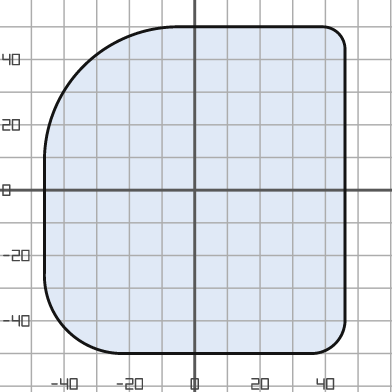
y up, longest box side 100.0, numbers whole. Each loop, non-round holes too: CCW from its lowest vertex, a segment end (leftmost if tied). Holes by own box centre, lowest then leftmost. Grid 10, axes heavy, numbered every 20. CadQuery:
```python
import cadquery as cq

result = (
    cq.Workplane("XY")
    .moveTo(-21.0, -50.0)
    .lineTo(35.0, -50.0)
    .threePointArc((43.0, -47.0), (46.0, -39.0))
    .lineTo(46.0, 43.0)
    .threePointArc((44.0, 48.0), (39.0, 50.0))
    .lineTo(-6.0, 50.0)
    .threePointArc((-34.0, 38.0), (-46.0, 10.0))
    .lineTo(-46.0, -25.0)
    .threePointArc((-39.0, -43.0), (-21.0, -50.0))
    .close()
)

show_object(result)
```